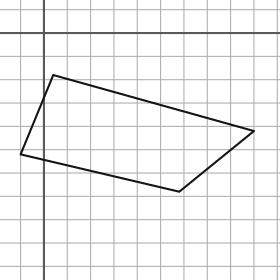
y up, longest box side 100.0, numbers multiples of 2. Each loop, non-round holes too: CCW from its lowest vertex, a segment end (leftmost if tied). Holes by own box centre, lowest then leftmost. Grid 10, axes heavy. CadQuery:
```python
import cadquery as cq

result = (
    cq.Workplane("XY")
    .moveTo(58.0, -68.0)
    .lineTo(90.0, -42.0)
    .lineTo(4.0, -18.0)
    .lineTo(-10.0, -52.0)
    .close()
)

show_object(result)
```